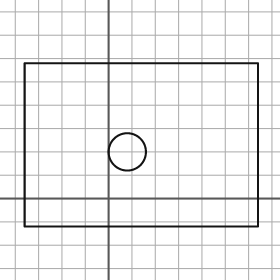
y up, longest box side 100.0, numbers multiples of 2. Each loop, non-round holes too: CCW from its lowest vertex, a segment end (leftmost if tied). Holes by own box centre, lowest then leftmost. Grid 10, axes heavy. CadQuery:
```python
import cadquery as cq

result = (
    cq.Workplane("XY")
    .moveTo(-36.0, -12.0)
    .lineTo(64.0, -12.0)
    .lineTo(64.0, 58.0)
    .lineTo(-36.0, 58.0)
    .close()
    .moveTo(8.0, 20.0)
    .circle(8.0)
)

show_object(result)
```